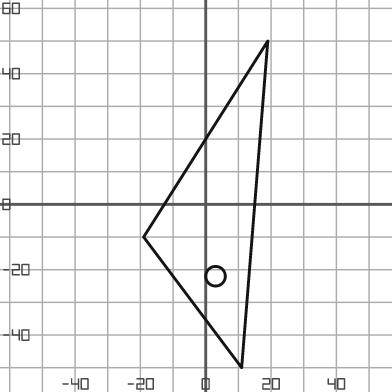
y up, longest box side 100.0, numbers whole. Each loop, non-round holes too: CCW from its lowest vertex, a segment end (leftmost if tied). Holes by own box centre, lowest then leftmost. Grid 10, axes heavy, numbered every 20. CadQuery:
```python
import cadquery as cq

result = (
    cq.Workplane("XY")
    .moveTo(11.0, -50.0)
    .lineTo(19.0, 50.0)
    .lineTo(-19.0, -10.0)
    .close()
    .moveTo(3.0, -22.0)
    .circle(3.0)
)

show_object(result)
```